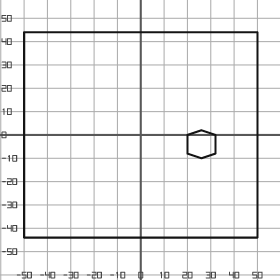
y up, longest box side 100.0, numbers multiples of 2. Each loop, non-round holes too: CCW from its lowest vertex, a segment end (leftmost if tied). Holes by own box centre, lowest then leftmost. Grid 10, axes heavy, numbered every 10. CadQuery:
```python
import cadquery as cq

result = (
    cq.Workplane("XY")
    .moveTo(-50.0, -44.0)
    .lineTo(50.0, -44.0)
    .lineTo(50.0, 44.0)
    .lineTo(-50.0, 44.0)
    .close()
    .moveTo(26.0, -10.0)
    .lineTo(32.0, -8.0)
    .lineTo(32.0, 0.0)
    .lineTo(26.0, 2.0)
    .lineTo(20.0, 0.0)
    .lineTo(20.0, -8.0)
    .close()
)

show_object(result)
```